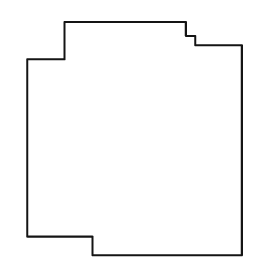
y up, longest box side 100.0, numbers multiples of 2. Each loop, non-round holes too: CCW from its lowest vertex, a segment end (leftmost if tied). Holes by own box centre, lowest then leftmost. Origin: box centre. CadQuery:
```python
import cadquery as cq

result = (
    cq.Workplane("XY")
    .moveTo(-18.0, -50.0)
    .lineTo(46.0, -50.0)
    .lineTo(46.0, 40.0)
    .lineTo(26.0, 40.0)
    .lineTo(26.0, 44.0)
    .lineTo(22.0, 44.0)
    .lineTo(22.0, 50.0)
    .lineTo(-30.0, 50.0)
    .lineTo(-30.0, 34.0)
    .lineTo(-46.0, 34.0)
    .lineTo(-46.0, -42.0)
    .lineTo(-18.0, -42.0)
    .close()
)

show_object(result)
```